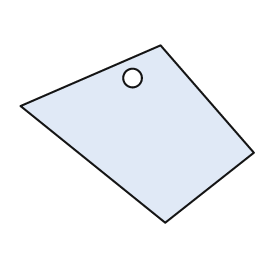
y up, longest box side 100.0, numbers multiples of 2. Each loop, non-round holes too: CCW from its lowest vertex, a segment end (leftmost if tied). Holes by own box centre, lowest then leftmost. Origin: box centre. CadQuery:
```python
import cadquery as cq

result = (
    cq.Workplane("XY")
    .moveTo(12.0, -38.0)
    .lineTo(50.0, -8.0)
    .lineTo(10.0, 38.0)
    .lineTo(-50.0, 12.0)
    .close()
    .moveTo(-2.0, 24.0)
    .circle(4.0)
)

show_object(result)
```